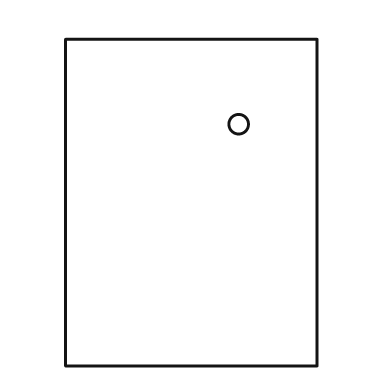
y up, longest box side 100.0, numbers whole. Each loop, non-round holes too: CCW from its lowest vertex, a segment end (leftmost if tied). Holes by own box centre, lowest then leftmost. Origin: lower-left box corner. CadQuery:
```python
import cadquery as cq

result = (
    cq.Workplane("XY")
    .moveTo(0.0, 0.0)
    .lineTo(77.0, 0.0)
    .lineTo(77.0, 100.0)
    .lineTo(0.0, 100.0)
    .close()
    .moveTo(53.0, 74.0)
    .circle(3.0)
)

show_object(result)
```